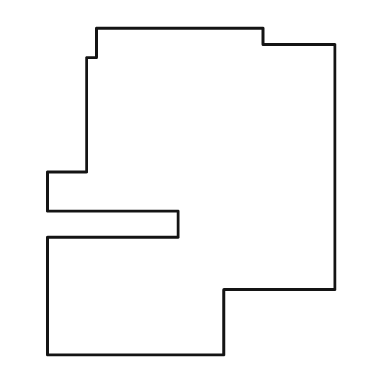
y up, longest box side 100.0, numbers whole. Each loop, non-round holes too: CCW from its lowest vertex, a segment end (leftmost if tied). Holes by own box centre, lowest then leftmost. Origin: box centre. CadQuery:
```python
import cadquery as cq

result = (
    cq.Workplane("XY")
    .moveTo(-44.0, -50.0)
    .lineTo(10.0, -50.0)
    .lineTo(10.0, -30.0)
    .lineTo(44.0, -30.0)
    .lineTo(44.0, 45.0)
    .lineTo(22.0, 45.0)
    .lineTo(22.0, 50.0)
    .lineTo(-29.0, 50.0)
    .lineTo(-29.0, 41.0)
    .lineTo(-32.0, 41.0)
    .lineTo(-32.0, 6.0)
    .lineTo(-44.0, 6.0)
    .lineTo(-44.0, -6.0)
    .lineTo(-4.0, -6.0)
    .lineTo(-4.0, -14.0)
    .lineTo(-44.0, -14.0)
    .close()
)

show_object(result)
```